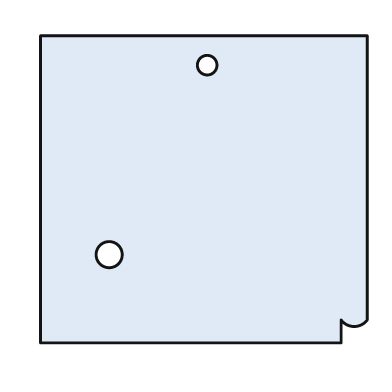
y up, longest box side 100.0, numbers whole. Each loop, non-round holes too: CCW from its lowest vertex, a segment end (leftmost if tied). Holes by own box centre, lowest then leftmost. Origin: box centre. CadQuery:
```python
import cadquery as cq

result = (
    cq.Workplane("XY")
    .moveTo(-50.0, -47.0)
    .lineTo(42.0, -47.0)
    .lineTo(42.0, -40.0)
    .threePointArc((46.0, -42.0), (50.0, -40.0))
    .lineTo(50.0, 47.0)
    .lineTo(-50.0, 47.0)
    .close()
    .moveTo(-29.0, -20.0)
    .circle(4.0)
    .moveTo(1.0, 38.0)
    .circle(3.0)
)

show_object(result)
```